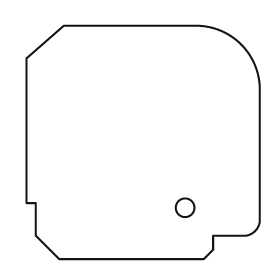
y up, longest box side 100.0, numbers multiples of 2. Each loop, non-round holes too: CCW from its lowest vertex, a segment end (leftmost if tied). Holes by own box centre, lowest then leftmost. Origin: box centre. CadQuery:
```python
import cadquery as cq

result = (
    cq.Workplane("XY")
    .moveTo(-36.0, -50.0)
    .lineTo(26.0, -50.0)
    .lineTo(30.0, -46.0)
    .lineTo(30.0, -40.0)
    .lineTo(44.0, -40.0)
    .threePointArc((48.0, -38.0), (50.0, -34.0))
    .lineTo(50.0, 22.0)
    .threePointArc((42.0, 42.0), (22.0, 50.0))
    .lineTo(-34.0, 50.0)
    .lineTo(-50.0, 36.0)
    .lineTo(-50.0, -26.0)
    .lineTo(-46.0, -26.0)
    .lineTo(-46.0, -40.0)
    .close()
    .moveTo(18.0, -28.0)
    .circle(4.0)
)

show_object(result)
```